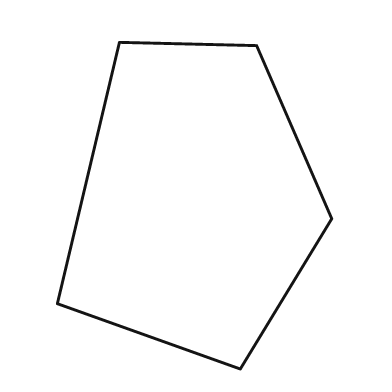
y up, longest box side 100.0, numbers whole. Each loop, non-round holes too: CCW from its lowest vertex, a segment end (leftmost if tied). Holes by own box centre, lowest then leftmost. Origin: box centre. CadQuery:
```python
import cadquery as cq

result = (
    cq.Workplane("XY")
    .moveTo(14.0, -50.0)
    .lineTo(42.0, -4.0)
    .lineTo(19.0, 49.0)
    .lineTo(-23.0, 50.0)
    .lineTo(-42.0, -30.0)
    .close()
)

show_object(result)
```